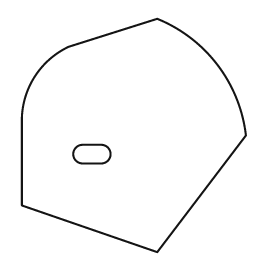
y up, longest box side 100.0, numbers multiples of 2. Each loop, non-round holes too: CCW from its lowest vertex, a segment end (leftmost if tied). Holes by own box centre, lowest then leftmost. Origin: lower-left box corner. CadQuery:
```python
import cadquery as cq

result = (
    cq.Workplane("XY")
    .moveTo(58.0, 0.0)
    .lineTo(96.0, 50.0)
    .threePointArc((84.0, 80.0), (58.0, 100.0))
    .lineTo(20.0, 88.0)
    .threePointArc((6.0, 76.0), (0.0, 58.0))
    .lineTo(0.0, 20.0)
    .close()
    .moveTo(26.0, 38.0)
    .lineTo(34.0, 38.0)
    .threePointArc((38.0, 42.0), (34.0, 46.0))
    .lineTo(26.0, 46.0)
    .threePointArc((22.0, 42.0), (26.0, 38.0))
    .close()
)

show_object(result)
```